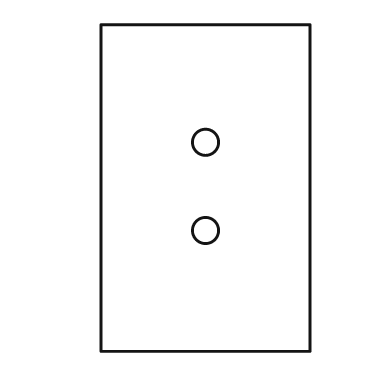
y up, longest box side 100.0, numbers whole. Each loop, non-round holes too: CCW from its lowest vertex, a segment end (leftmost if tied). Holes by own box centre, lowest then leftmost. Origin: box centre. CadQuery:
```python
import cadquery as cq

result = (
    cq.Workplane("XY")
    .moveTo(-32.0, -50.0)
    .lineTo(32.0, -50.0)
    .lineTo(32.0, 50.0)
    .lineTo(-32.0, 50.0)
    .close()
    .moveTo(0.0, -13.0)
    .circle(4.0)
    .moveTo(0.0, 14.0)
    .circle(4.0)
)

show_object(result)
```